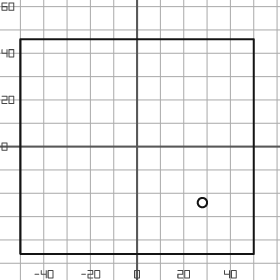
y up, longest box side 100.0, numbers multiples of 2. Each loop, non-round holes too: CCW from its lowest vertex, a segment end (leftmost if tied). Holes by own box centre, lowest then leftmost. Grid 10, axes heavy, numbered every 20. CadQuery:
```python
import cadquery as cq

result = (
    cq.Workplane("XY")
    .moveTo(-50.0, -46.0)
    .lineTo(50.0, -46.0)
    .lineTo(50.0, 46.0)
    .lineTo(-50.0, 46.0)
    .close()
    .moveTo(28.0, -24.0)
    .circle(2.0)
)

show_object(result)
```